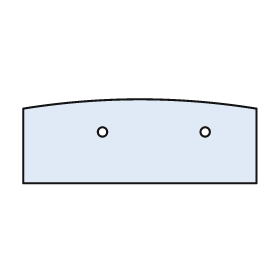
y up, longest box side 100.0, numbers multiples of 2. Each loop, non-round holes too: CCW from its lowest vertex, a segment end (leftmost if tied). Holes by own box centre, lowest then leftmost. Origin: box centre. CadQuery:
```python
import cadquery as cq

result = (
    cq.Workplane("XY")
    .moveTo(-50.0, -18.0)
    .lineTo(50.0, -18.0)
    .lineTo(50.0, 14.0)
    .threePointArc((0.0, 18.0), (-50.0, 14.0))
    .close()
    .moveTo(-16.0, 4.0)
    .circle(2.0)
    .moveTo(28.0, 4.0)
    .circle(2.0)
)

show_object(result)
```